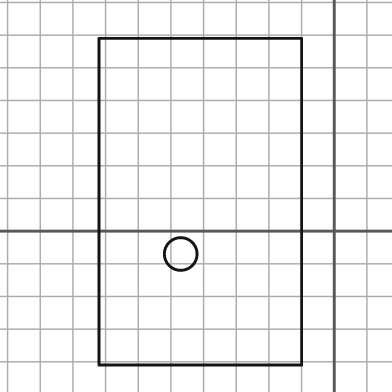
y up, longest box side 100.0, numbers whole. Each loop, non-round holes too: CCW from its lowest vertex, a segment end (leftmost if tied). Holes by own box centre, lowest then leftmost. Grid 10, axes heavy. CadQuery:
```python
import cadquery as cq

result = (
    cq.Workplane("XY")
    .moveTo(-72.0, -41.0)
    .lineTo(-10.0, -41.0)
    .lineTo(-10.0, 59.0)
    .lineTo(-72.0, 59.0)
    .close()
    .moveTo(-47.0, -7.0)
    .circle(5.0)
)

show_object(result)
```